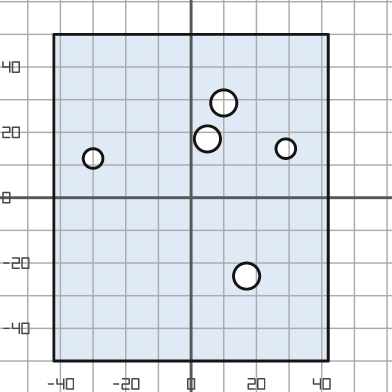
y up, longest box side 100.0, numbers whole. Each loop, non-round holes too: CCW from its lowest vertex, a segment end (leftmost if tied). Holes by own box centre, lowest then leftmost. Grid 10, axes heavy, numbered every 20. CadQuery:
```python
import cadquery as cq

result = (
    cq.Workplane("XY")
    .moveTo(-42.0, -50.0)
    .lineTo(42.0, -50.0)
    .lineTo(42.0, 50.0)
    .lineTo(-42.0, 50.0)
    .close()
    .moveTo(17.0, -24.0)
    .circle(4.0)
    .moveTo(-30.0, 12.0)
    .circle(3.0)
    .moveTo(29.0, 15.0)
    .circle(3.0)
    .moveTo(5.0, 18.0)
    .circle(4.0)
    .moveTo(10.0, 29.0)
    .circle(4.0)
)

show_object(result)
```